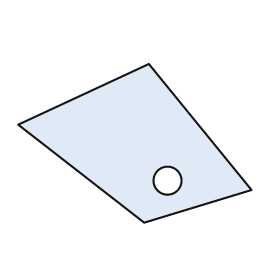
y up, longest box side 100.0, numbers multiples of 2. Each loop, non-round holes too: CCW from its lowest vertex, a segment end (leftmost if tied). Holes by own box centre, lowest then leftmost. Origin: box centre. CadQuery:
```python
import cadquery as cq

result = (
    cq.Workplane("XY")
    .moveTo(4.0, -34.0)
    .lineTo(50.0, -20.0)
    .lineTo(6.0, 34.0)
    .lineTo(-50.0, 8.0)
    .close()
    .moveTo(14.0, -16.0)
    .circle(6.0)
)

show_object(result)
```